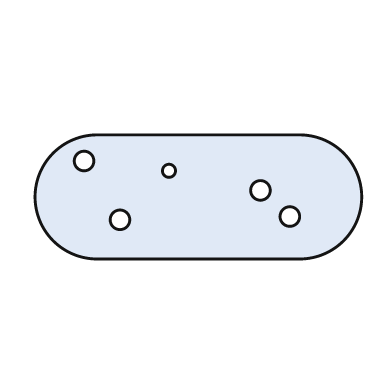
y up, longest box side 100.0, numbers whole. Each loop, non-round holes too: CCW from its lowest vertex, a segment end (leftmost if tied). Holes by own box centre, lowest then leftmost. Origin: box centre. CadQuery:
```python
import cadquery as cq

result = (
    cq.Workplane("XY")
    .moveTo(-31.0, -19.0)
    .lineTo(31.0, -19.0)
    .threePointArc((50.0, 0.0), (31.0, 19.0))
    .lineTo(-31.0, 19.0)
    .threePointArc((-50.0, 0.0), (-31.0, -19.0))
    .close()
    .moveTo(-24.0, -7.0)
    .circle(3.0)
    .moveTo(28.0, -6.0)
    .circle(3.0)
    .moveTo(19.0, 2.0)
    .circle(3.0)
    .moveTo(-9.0, 8.0)
    .circle(2.0)
    .moveTo(-35.0, 11.0)
    .circle(3.0)
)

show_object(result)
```